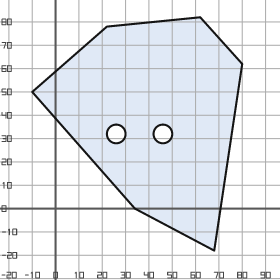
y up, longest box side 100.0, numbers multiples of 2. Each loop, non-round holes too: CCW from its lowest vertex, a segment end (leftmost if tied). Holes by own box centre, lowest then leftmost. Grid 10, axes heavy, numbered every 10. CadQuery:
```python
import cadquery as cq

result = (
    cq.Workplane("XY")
    .moveTo(68.0, -18.0)
    .lineTo(80.0, 62.0)
    .lineTo(62.0, 82.0)
    .lineTo(22.0, 78.0)
    .lineTo(-10.0, 50.0)
    .lineTo(34.0, 0.0)
    .close()
    .moveTo(26.0, 32.0)
    .circle(4.0)
    .moveTo(46.0, 32.0)
    .circle(4.0)
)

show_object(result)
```